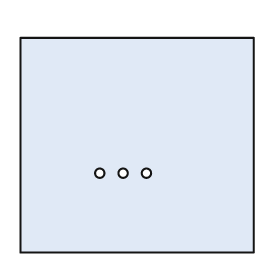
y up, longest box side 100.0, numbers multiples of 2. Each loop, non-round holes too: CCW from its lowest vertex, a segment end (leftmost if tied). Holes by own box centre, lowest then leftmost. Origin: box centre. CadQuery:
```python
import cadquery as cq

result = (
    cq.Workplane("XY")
    .moveTo(-50.0, -46.0)
    .lineTo(50.0, -46.0)
    .lineTo(50.0, 46.0)
    .lineTo(-50.0, 46.0)
    .close()
    .moveTo(-16.0, -12.0)
    .circle(2.0)
    .moveTo(-6.0, -12.0)
    .circle(2.0)
    .moveTo(4.0, -12.0)
    .circle(2.0)
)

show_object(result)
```